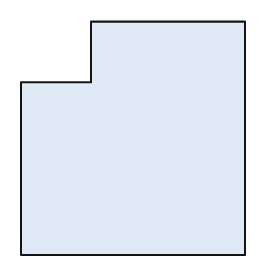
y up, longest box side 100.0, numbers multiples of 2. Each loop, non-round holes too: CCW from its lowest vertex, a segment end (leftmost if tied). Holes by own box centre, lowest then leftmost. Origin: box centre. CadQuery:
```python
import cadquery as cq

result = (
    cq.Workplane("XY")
    .moveTo(-48.0, -50.0)
    .lineTo(48.0, -50.0)
    .lineTo(48.0, 50.0)
    .lineTo(-18.0, 50.0)
    .lineTo(-18.0, 24.0)
    .lineTo(-48.0, 24.0)
    .close()
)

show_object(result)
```